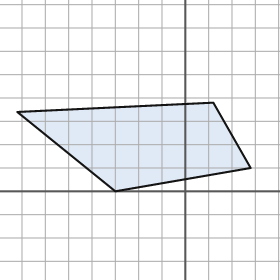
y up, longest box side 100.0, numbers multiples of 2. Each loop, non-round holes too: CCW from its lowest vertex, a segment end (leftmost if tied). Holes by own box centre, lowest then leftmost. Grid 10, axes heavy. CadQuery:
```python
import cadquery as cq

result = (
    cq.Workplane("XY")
    .moveTo(-30.0, 0.0)
    .lineTo(28.0, 10.0)
    .lineTo(12.0, 38.0)
    .lineTo(-72.0, 34.0)
    .close()
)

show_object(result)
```